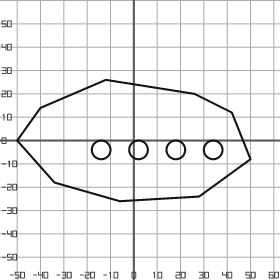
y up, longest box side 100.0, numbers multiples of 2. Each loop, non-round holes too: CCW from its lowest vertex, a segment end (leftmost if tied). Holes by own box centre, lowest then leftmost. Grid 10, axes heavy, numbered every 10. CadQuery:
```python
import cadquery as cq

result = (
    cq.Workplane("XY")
    .moveTo(-6.0, -26.0)
    .lineTo(28.0, -24.0)
    .lineTo(50.0, -8.0)
    .lineTo(42.0, 12.0)
    .lineTo(26.0, 20.0)
    .lineTo(-12.0, 26.0)
    .lineTo(-40.0, 14.0)
    .lineTo(-50.0, 0.0)
    .lineTo(-34.0, -18.0)
    .close()
    .moveTo(-14.0, -4.0)
    .circle(4.0)
    .moveTo(2.0, -4.0)
    .circle(4.0)
    .moveTo(18.0, -4.0)
    .circle(4.0)
    .moveTo(34.0, -4.0)
    .circle(4.0)
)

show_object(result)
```